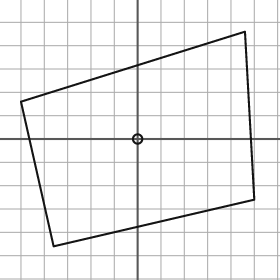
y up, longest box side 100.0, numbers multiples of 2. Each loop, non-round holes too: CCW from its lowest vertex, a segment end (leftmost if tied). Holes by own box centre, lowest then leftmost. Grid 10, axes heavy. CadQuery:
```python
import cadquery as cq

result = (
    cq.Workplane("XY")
    .moveTo(-36.0, -46.0)
    .lineTo(50.0, -26.0)
    .lineTo(46.0, 46.0)
    .lineTo(-50.0, 16.0)
    .close()
    .moveTo(0.0, 0.0)
    .circle(2.0)
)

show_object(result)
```